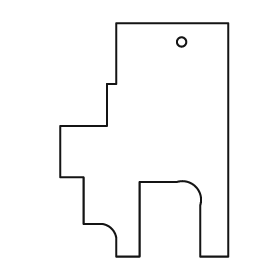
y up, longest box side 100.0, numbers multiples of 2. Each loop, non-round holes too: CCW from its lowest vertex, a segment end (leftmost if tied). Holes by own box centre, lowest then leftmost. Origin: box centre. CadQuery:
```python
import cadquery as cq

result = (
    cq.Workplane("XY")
    .moveTo(-12.0, -50.0)
    .lineTo(-2.0, -50.0)
    .lineTo(-2.0, -18.0)
    .lineTo(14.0, -18.0)
    .threePointArc((22.0, -20.0), (24.0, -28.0))
    .lineTo(24.0, -50.0)
    .lineTo(36.0, -50.0)
    .lineTo(36.0, 50.0)
    .lineTo(-12.0, 50.0)
    .lineTo(-12.0, 24.0)
    .lineTo(-16.0, 24.0)
    .lineTo(-16.0, 6.0)
    .lineTo(-36.0, 6.0)
    .lineTo(-36.0, -16.0)
    .lineTo(-26.0, -16.0)
    .lineTo(-26.0, -36.0)
    .lineTo(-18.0, -36.0)
    .threePointArc((-14.0, -38.0), (-12.0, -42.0))
    .close()
    .moveTo(16.0, 42.0)
    .circle(2.0)
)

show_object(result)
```